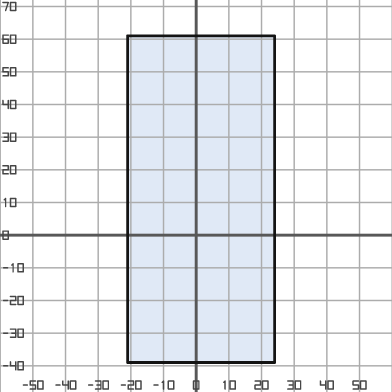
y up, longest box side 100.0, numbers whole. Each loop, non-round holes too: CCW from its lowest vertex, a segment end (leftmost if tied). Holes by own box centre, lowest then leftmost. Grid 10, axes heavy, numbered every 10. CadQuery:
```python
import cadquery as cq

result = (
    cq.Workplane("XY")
    .moveTo(-21.0, -39.0)
    .lineTo(24.0, -39.0)
    .lineTo(24.0, 61.0)
    .lineTo(-21.0, 61.0)
    .close()
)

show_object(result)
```